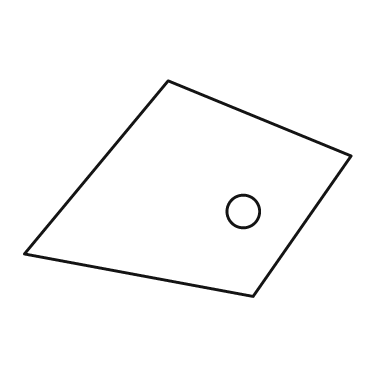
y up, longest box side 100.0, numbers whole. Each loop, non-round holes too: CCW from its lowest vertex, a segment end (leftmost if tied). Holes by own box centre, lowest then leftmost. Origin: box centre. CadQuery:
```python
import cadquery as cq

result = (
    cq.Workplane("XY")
    .moveTo(20.0, -33.0)
    .lineTo(50.0, 10.0)
    .lineTo(-6.0, 33.0)
    .lineTo(-50.0, -20.0)
    .close()
    .moveTo(17.0, -7.0)
    .circle(5.0)
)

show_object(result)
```